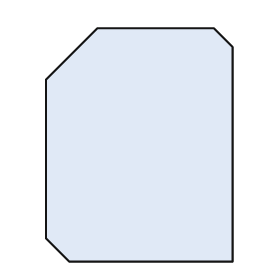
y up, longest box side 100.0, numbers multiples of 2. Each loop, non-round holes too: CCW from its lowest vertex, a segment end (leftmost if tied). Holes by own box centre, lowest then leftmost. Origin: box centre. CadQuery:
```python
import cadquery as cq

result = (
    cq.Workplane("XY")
    .moveTo(-30.0, -50.0)
    .lineTo(40.0, -50.0)
    .lineTo(40.0, 42.0)
    .lineTo(32.0, 50.0)
    .lineTo(-18.0, 50.0)
    .lineTo(-40.0, 28.0)
    .lineTo(-40.0, -40.0)
    .close()
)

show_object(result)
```